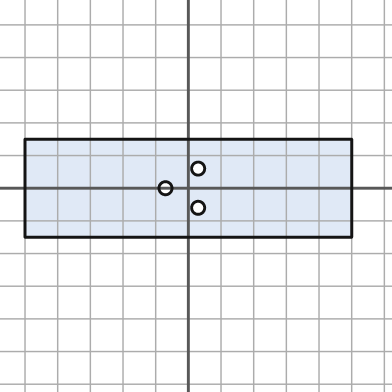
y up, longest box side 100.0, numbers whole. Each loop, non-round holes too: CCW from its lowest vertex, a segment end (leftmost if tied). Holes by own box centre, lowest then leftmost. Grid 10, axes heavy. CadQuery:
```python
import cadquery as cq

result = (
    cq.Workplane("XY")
    .moveTo(-50.0, -15.0)
    .lineTo(50.0, -15.0)
    .lineTo(50.0, 15.0)
    .lineTo(-50.0, 15.0)
    .close()
    .moveTo(3.0, -6.0)
    .circle(2.0)
    .moveTo(-7.0, 0.0)
    .circle(2.0)
    .moveTo(3.0, 6.0)
    .circle(2.0)
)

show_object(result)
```